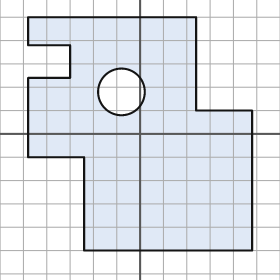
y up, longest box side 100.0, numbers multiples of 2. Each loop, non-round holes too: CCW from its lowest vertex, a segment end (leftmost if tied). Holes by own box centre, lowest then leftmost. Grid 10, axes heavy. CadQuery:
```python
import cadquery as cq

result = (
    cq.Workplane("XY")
    .moveTo(-24.0, -50.0)
    .lineTo(48.0, -50.0)
    .lineTo(48.0, 10.0)
    .lineTo(24.0, 10.0)
    .lineTo(24.0, 50.0)
    .lineTo(-48.0, 50.0)
    .lineTo(-48.0, 38.0)
    .lineTo(-30.0, 38.0)
    .lineTo(-30.0, 24.0)
    .lineTo(-48.0, 24.0)
    .lineTo(-48.0, -10.0)
    .lineTo(-24.0, -10.0)
    .close()
    .moveTo(-8.0, 18.0)
    .circle(10.0)
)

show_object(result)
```